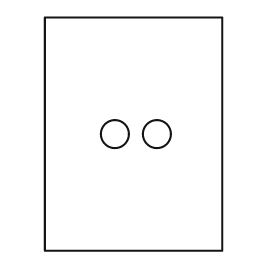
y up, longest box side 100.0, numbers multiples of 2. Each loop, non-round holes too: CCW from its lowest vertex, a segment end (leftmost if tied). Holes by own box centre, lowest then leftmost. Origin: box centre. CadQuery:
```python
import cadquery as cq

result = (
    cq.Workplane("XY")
    .moveTo(-38.0, -50.0)
    .lineTo(38.0, -50.0)
    .lineTo(38.0, 50.0)
    .lineTo(-38.0, 50.0)
    .close()
    .moveTo(-8.0, 0.0)
    .circle(6.0)
    .moveTo(10.0, 0.0)
    .circle(6.0)
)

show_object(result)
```